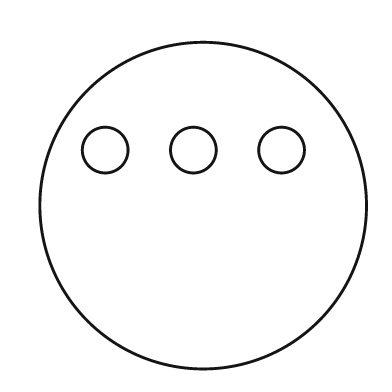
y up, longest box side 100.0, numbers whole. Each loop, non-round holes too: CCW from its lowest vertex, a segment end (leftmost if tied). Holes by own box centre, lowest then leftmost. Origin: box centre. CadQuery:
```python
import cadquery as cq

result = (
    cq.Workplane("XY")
    .moveTo(0.0, 0.0)
    .circle(50.0)
    .moveTo(-30.0, 17.0)
    .circle(7.0)
    .moveTo(-3.0, 17.0)
    .circle(7.0)
    .moveTo(24.0, 17.0)
    .circle(7.0)
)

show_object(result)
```